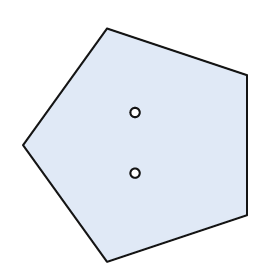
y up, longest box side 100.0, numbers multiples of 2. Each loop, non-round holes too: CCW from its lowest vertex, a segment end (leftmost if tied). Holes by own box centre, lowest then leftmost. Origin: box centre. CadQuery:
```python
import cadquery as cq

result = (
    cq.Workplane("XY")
    .moveTo(-12.0, -50.0)
    .lineTo(48.0, -30.0)
    .lineTo(48.0, 30.0)
    .lineTo(-12.0, 50.0)
    .lineTo(-48.0, 0.0)
    .close()
    .moveTo(0.0, -12.0)
    .circle(2.0)
    .moveTo(0.0, 14.0)
    .circle(2.0)
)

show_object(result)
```